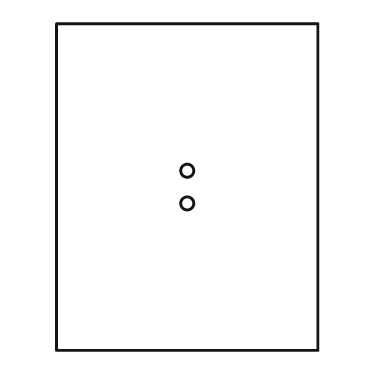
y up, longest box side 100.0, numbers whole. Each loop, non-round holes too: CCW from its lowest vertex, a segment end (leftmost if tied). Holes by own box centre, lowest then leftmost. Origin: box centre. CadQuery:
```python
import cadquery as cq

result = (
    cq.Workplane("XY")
    .moveTo(-40.0, -50.0)
    .lineTo(40.0, -50.0)
    .lineTo(40.0, 50.0)
    .lineTo(-40.0, 50.0)
    .close()
    .moveTo(0.0, -5.0)
    .circle(2.0)
    .moveTo(0.0, 5.0)
    .circle(2.0)
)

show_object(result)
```